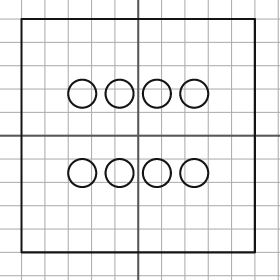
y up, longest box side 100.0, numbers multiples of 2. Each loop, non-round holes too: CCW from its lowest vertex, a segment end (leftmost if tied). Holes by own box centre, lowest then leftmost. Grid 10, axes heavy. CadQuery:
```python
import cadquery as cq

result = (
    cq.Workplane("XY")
    .moveTo(-50.0, -50.0)
    .lineTo(50.0, -50.0)
    .lineTo(50.0, 50.0)
    .lineTo(-50.0, 50.0)
    .close()
    .moveTo(-24.0, -16.0)
    .circle(6.0)
    .moveTo(-8.0, -16.0)
    .circle(6.0)
    .moveTo(8.0, -16.0)
    .circle(6.0)
    .moveTo(24.0, -16.0)
    .circle(6.0)
    .moveTo(-24.0, 18.0)
    .circle(6.0)
    .moveTo(-8.0, 18.0)
    .circle(6.0)
    .moveTo(8.0, 18.0)
    .circle(6.0)
    .moveTo(24.0, 18.0)
    .circle(6.0)
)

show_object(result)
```